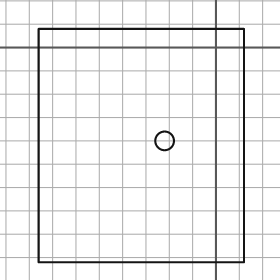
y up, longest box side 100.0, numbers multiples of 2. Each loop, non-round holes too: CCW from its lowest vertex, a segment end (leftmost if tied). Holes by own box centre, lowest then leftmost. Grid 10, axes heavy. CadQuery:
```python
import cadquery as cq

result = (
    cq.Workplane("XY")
    .moveTo(-76.0, -92.0)
    .lineTo(12.0, -92.0)
    .lineTo(12.0, 8.0)
    .lineTo(-76.0, 8.0)
    .close()
    .moveTo(-22.0, -40.0)
    .circle(4.0)
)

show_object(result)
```